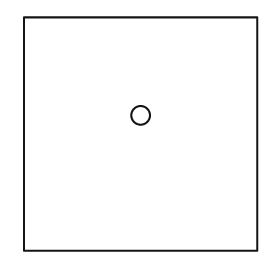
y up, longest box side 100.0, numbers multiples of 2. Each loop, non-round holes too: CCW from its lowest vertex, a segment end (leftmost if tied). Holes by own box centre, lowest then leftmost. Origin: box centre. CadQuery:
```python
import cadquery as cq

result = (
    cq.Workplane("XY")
    .moveTo(-50.0, -50.0)
    .lineTo(50.0, -50.0)
    .lineTo(50.0, 50.0)
    .lineTo(-50.0, 50.0)
    .close()
    .moveTo(0.0, 8.0)
    .circle(4.0)
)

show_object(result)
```